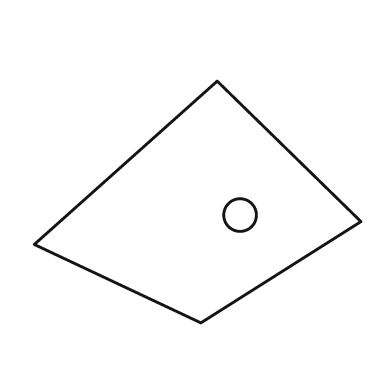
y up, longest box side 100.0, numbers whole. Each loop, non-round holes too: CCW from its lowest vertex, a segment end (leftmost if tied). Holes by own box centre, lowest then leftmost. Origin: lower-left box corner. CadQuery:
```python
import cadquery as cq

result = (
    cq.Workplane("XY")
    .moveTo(51.0, 0.0)
    .lineTo(100.0, 31.0)
    .lineTo(56.0, 74.0)
    .lineTo(0.0, 24.0)
    .close()
    .moveTo(63.0, 33.0)
    .circle(5.0)
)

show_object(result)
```